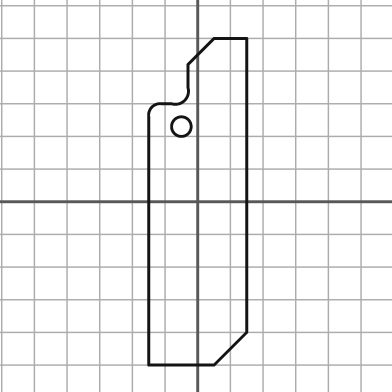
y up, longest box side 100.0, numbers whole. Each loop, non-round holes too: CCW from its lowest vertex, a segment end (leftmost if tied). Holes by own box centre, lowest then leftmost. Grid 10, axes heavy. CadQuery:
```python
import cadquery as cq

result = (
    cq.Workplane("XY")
    .moveTo(-15.0, -50.0)
    .lineTo(5.0, -50.0)
    .lineTo(15.0, -40.0)
    .lineTo(15.0, 50.0)
    .lineTo(5.0, 50.0)
    .lineTo(-3.0, 42.0)
    .lineTo(-3.0, 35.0)
    .threePointArc((-4.0, 31.0), (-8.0, 30.0))
    .lineTo(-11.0, 30.0)
    .threePointArc((-14.0, 29.0), (-15.0, 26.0))
    .close()
    .moveTo(-5.0, 23.0)
    .circle(3.0)
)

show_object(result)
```